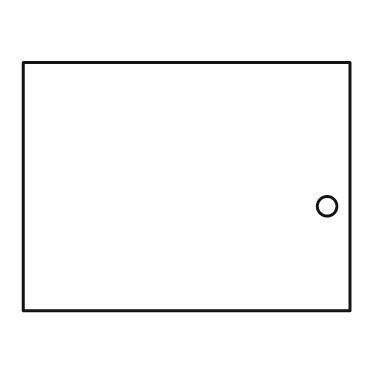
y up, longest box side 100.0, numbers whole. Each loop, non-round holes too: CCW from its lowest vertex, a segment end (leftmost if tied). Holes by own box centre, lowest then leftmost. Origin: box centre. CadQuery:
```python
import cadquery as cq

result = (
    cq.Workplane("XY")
    .moveTo(-50.0, -38.0)
    .lineTo(50.0, -38.0)
    .lineTo(50.0, 38.0)
    .lineTo(-50.0, 38.0)
    .close()
    .moveTo(43.0, -6.0)
    .circle(3.0)
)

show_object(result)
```